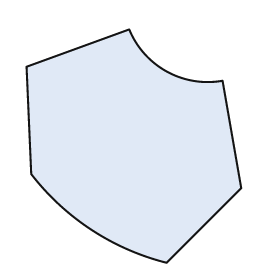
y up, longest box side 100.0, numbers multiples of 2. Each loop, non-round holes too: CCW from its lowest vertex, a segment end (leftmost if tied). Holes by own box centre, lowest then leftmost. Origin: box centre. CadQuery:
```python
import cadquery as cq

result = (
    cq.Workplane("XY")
    .moveTo(14.0, -50.0)
    .lineTo(46.0, -18.0)
    .lineTo(38.0, 28.0)
    .threePointArc((14.0, 32.0), (-2.0, 50.0))
    .lineTo(-46.0, 34.0)
    .lineTo(-44.0, -12.0)
    .threePointArc((-18.0, -36.0), (14.0, -50.0))
    .close()
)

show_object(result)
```